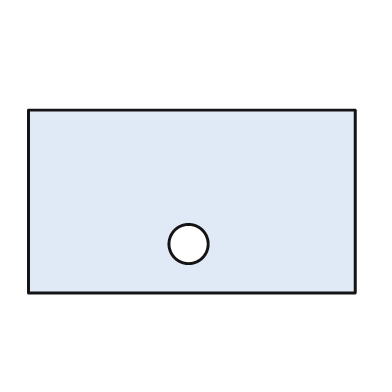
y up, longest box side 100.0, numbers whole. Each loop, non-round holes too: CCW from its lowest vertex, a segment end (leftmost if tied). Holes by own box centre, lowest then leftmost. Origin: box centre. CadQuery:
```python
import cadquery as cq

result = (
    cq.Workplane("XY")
    .moveTo(-50.0, -28.0)
    .lineTo(50.0, -28.0)
    .lineTo(50.0, 28.0)
    .lineTo(-50.0, 28.0)
    .close()
    .moveTo(-1.0, -13.0)
    .circle(6.0)
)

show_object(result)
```